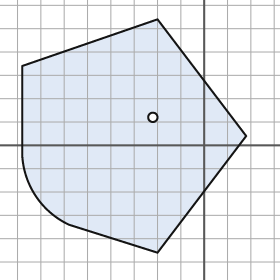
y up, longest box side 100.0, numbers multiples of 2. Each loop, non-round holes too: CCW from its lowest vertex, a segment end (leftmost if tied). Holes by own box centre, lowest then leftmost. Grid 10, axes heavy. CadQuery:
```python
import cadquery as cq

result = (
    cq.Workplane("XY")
    .moveTo(-20.0, -46.0)
    .lineTo(18.0, 4.0)
    .lineTo(-20.0, 54.0)
    .lineTo(-78.0, 34.0)
    .lineTo(-78.0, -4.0)
    .threePointArc((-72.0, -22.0), (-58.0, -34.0))
    .close()
    .moveTo(-22.0, 12.0)
    .circle(2.0)
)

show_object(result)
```